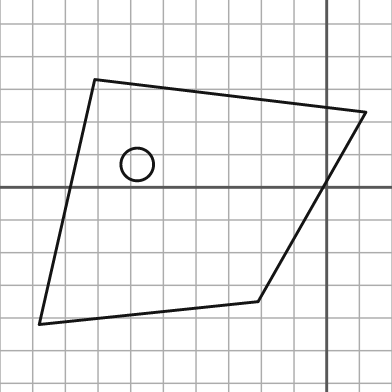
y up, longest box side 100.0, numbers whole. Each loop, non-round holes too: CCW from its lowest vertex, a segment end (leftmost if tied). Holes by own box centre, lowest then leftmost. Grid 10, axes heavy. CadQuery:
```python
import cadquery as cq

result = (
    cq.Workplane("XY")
    .moveTo(-88.0, -42.0)
    .lineTo(-21.0, -35.0)
    .lineTo(12.0, 23.0)
    .lineTo(-71.0, 33.0)
    .close()
    .moveTo(-58.0, 7.0)
    .circle(5.0)
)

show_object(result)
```